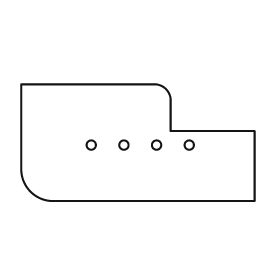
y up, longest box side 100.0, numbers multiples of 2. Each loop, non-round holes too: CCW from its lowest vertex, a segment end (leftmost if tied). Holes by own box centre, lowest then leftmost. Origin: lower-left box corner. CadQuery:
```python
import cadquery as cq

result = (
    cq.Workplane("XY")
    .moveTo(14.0, 0.0)
    .lineTo(100.0, 0.0)
    .lineTo(100.0, 30.0)
    .lineTo(64.0, 30.0)
    .lineTo(64.0, 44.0)
    .threePointArc((62.0, 48.0), (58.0, 50.0))
    .lineTo(0.0, 50.0)
    .lineTo(0.0, 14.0)
    .threePointArc((4.0, 4.0), (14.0, 0.0))
    .close()
    .moveTo(30.0, 24.0)
    .circle(2.0)
    .moveTo(44.0, 24.0)
    .circle(2.0)
    .moveTo(58.0, 24.0)
    .circle(2.0)
    .moveTo(72.0, 24.0)
    .circle(2.0)
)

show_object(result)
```